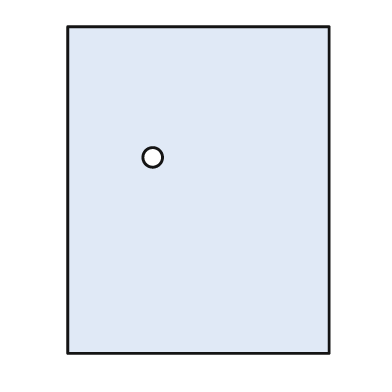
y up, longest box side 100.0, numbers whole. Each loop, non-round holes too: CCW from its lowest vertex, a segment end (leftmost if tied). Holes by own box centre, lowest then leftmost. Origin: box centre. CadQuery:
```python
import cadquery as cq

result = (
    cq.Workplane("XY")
    .moveTo(-40.0, -50.0)
    .lineTo(40.0, -50.0)
    .lineTo(40.0, 50.0)
    .lineTo(-40.0, 50.0)
    .close()
    .moveTo(-14.0, 10.0)
    .circle(3.0)
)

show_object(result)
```